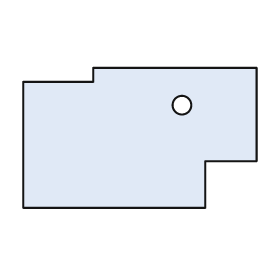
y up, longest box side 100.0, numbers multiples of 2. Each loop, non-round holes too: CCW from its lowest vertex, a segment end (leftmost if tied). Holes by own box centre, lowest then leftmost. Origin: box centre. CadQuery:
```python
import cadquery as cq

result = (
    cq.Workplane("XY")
    .moveTo(-50.0, -30.0)
    .lineTo(28.0, -30.0)
    .lineTo(28.0, -10.0)
    .lineTo(50.0, -10.0)
    .lineTo(50.0, 30.0)
    .lineTo(-20.0, 30.0)
    .lineTo(-20.0, 24.0)
    .lineTo(-50.0, 24.0)
    .close()
    .moveTo(18.0, 14.0)
    .circle(4.0)
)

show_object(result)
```